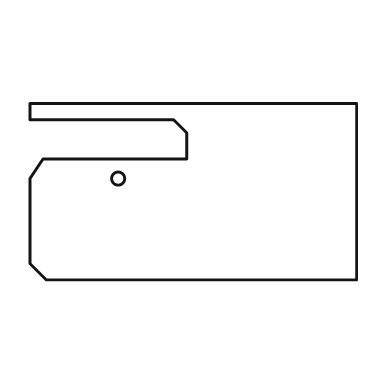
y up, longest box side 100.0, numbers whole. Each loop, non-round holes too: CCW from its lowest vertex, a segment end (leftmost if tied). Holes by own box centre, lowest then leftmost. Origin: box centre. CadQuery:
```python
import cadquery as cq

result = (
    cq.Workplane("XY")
    .moveTo(-45.0, -27.0)
    .lineTo(50.0, -27.0)
    .lineTo(50.0, 27.0)
    .lineTo(-50.0, 27.0)
    .lineTo(-50.0, 22.0)
    .lineTo(-6.0, 22.0)
    .lineTo(-2.0, 18.0)
    .lineTo(-2.0, 10.0)
    .lineTo(-46.0, 10.0)
    .lineTo(-50.0, 4.0)
    .lineTo(-50.0, -22.0)
    .close()
    .moveTo(-23.0, 4.0)
    .circle(2.0)
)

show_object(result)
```